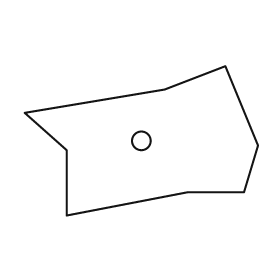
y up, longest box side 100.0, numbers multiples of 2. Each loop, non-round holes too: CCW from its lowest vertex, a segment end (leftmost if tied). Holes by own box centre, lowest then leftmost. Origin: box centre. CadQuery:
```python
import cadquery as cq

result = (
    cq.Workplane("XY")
    .moveTo(-32.0, -32.0)
    .lineTo(20.0, -22.0)
    .lineTo(44.0, -22.0)
    .lineTo(50.0, -2.0)
    .lineTo(36.0, 32.0)
    .lineTo(10.0, 22.0)
    .lineTo(-50.0, 12.0)
    .lineTo(-32.0, -4.0)
    .close()
    .moveTo(0.0, 0.0)
    .circle(4.0)
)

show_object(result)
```